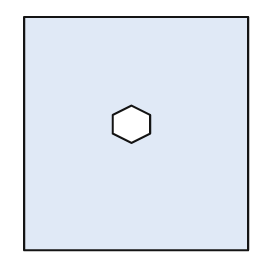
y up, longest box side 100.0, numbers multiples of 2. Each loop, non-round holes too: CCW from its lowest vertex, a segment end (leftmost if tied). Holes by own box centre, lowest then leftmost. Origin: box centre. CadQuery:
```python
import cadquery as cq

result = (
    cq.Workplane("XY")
    .moveTo(-48.0, -50.0)
    .lineTo(48.0, -50.0)
    .lineTo(48.0, 50.0)
    .lineTo(-48.0, 50.0)
    .close()
    .moveTo(-2.0, -4.0)
    .lineTo(6.0, 0.0)
    .lineTo(6.0, 8.0)
    .lineTo(-2.0, 12.0)
    .lineTo(-10.0, 8.0)
    .lineTo(-10.0, 0.0)
    .close()
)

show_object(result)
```